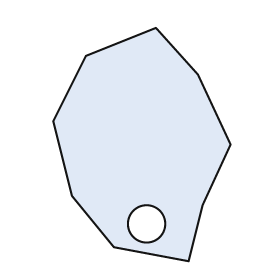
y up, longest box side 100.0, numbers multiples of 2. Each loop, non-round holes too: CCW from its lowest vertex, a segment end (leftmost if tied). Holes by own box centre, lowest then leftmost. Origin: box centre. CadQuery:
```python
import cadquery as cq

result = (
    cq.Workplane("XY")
    .moveTo(20.0, -50.0)
    .lineTo(26.0, -26.0)
    .lineTo(38.0, 0.0)
    .lineTo(24.0, 30.0)
    .lineTo(6.0, 50.0)
    .lineTo(-24.0, 38.0)
    .lineTo(-38.0, 10.0)
    .lineTo(-30.0, -22.0)
    .lineTo(-12.0, -44.0)
    .close()
    .moveTo(2.0, -34.0)
    .circle(8.0)
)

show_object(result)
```